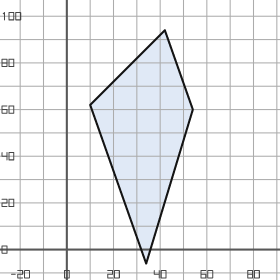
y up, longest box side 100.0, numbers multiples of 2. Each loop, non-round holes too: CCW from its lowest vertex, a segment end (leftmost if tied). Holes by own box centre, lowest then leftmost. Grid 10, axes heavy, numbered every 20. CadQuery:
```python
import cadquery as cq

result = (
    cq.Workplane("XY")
    .moveTo(34.0, -6.0)
    .lineTo(54.0, 60.0)
    .lineTo(42.0, 94.0)
    .lineTo(10.0, 62.0)
    .close()
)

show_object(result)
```